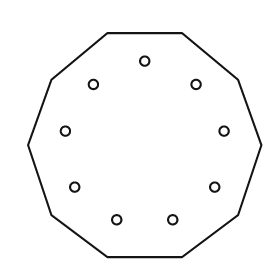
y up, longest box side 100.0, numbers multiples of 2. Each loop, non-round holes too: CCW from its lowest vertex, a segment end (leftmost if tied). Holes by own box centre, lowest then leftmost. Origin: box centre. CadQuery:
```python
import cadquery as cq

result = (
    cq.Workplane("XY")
    .moveTo(-16.0, -48.0)
    .lineTo(16.0, -48.0)
    .lineTo(40.0, -30.0)
    .lineTo(50.0, 0.0)
    .lineTo(40.0, 28.0)
    .lineTo(16.0, 48.0)
    .lineTo(-16.0, 48.0)
    .lineTo(-40.0, 28.0)
    .lineTo(-50.0, 0.0)
    .lineTo(-40.0, -30.0)
    .close()
    .moveTo(-12.0, -32.0)
    .circle(2.0)
    .moveTo(12.0, -32.0)
    .circle(2.0)
    .moveTo(-30.0, -18.0)
    .circle(2.0)
    .moveTo(30.0, -18.0)
    .circle(2.0)
    .moveTo(-34.0, 6.0)
    .circle(2.0)
    .moveTo(34.0, 6.0)
    .circle(2.0)
    .moveTo(-22.0, 26.0)
    .circle(2.0)
    .moveTo(22.0, 26.0)
    .circle(2.0)
    .moveTo(0.0, 36.0)
    .circle(2.0)
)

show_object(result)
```